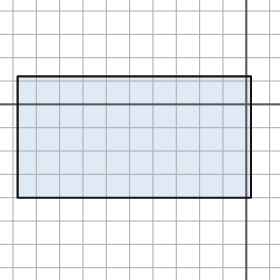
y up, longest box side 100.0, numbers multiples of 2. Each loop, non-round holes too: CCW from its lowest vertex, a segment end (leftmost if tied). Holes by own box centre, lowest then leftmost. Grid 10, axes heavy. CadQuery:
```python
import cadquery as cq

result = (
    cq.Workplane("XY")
    .moveTo(-98.0, -40.0)
    .lineTo(2.0, -40.0)
    .lineTo(2.0, 12.0)
    .lineTo(-98.0, 12.0)
    .close()
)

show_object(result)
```